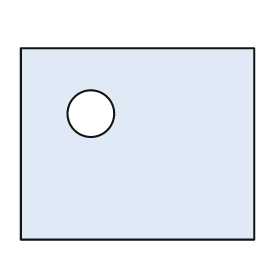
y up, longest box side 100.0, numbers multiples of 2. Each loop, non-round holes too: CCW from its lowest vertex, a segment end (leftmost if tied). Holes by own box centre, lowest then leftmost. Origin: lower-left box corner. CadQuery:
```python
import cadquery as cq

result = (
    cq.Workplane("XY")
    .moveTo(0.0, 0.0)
    .lineTo(100.0, 0.0)
    .lineTo(100.0, 82.0)
    .lineTo(0.0, 82.0)
    .close()
    .moveTo(30.0, 54.0)
    .circle(10.0)
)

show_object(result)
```